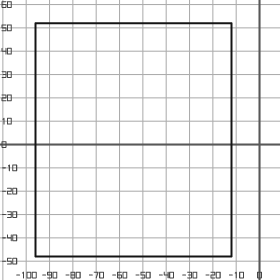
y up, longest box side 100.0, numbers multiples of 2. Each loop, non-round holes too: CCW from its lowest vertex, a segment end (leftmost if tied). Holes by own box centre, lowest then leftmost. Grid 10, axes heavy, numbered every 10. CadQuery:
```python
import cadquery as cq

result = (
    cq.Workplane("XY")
    .moveTo(-96.0, -48.0)
    .lineTo(-12.0, -48.0)
    .lineTo(-12.0, 52.0)
    .lineTo(-96.0, 52.0)
    .close()
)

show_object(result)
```